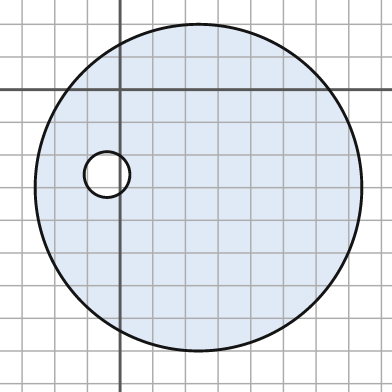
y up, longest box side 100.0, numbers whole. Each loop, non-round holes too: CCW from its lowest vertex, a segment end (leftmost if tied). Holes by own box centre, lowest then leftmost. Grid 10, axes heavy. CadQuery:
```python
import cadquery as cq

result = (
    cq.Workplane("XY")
    .moveTo(24.0, -30.0)
    .circle(50.0)
    .moveTo(-4.0, -26.0)
    .circle(7.0)
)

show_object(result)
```